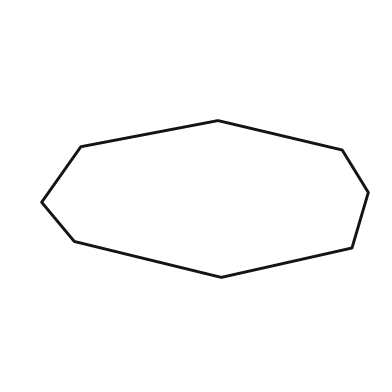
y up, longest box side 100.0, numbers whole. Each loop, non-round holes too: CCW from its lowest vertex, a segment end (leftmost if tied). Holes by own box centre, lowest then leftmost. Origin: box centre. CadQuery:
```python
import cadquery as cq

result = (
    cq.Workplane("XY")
    .moveTo(5.0, -24.0)
    .lineTo(45.0, -15.0)
    .lineTo(50.0, 2.0)
    .lineTo(42.0, 15.0)
    .lineTo(4.0, 24.0)
    .lineTo(-38.0, 16.0)
    .lineTo(-50.0, -1.0)
    .lineTo(-40.0, -13.0)
    .close()
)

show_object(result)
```